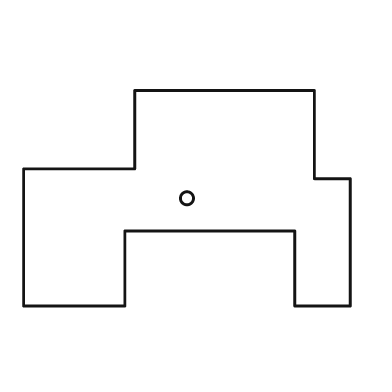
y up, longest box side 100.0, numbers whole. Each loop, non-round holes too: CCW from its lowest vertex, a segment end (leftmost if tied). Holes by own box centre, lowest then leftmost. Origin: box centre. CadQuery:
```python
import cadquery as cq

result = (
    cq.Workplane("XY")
    .moveTo(-50.0, -33.0)
    .lineTo(-19.0, -33.0)
    .lineTo(-19.0, -10.0)
    .lineTo(33.0, -10.0)
    .lineTo(33.0, -33.0)
    .lineTo(50.0, -33.0)
    .lineTo(50.0, 6.0)
    .lineTo(39.0, 6.0)
    .lineTo(39.0, 33.0)
    .lineTo(-16.0, 33.0)
    .lineTo(-16.0, 9.0)
    .lineTo(-50.0, 9.0)
    .close()
    .moveTo(0.0, 0.0)
    .circle(2.0)
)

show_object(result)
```